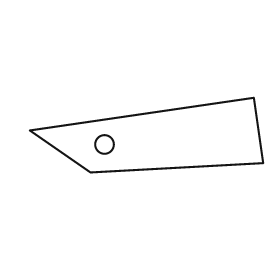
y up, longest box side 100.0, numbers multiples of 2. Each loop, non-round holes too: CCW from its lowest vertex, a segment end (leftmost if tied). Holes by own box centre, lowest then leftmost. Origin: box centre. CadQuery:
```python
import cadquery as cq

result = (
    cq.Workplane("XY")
    .moveTo(-24.0, -16.0)
    .lineTo(50.0, -12.0)
    .lineTo(46.0, 16.0)
    .lineTo(-50.0, 2.0)
    .close()
    .moveTo(-18.0, -4.0)
    .circle(4.0)
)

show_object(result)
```